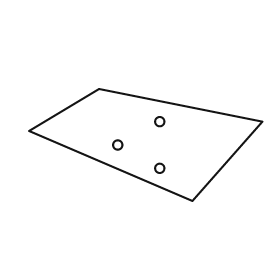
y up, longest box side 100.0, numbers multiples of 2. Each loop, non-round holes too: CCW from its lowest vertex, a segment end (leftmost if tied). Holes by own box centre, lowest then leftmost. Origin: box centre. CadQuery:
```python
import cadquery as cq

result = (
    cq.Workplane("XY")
    .moveTo(20.0, -24.0)
    .lineTo(50.0, 10.0)
    .lineTo(-20.0, 24.0)
    .lineTo(-50.0, 6.0)
    .close()
    .moveTo(6.0, -10.0)
    .circle(2.0)
    .moveTo(-12.0, 0.0)
    .circle(2.0)
    .moveTo(6.0, 10.0)
    .circle(2.0)
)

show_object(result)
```